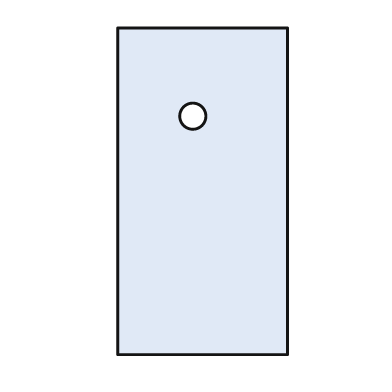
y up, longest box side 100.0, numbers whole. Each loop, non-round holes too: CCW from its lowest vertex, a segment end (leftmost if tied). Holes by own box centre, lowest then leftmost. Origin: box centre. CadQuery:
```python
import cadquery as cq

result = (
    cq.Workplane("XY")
    .moveTo(-26.0, -50.0)
    .lineTo(26.0, -50.0)
    .lineTo(26.0, 50.0)
    .lineTo(-26.0, 50.0)
    .close()
    .moveTo(-3.0, 23.0)
    .circle(4.0)
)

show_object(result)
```